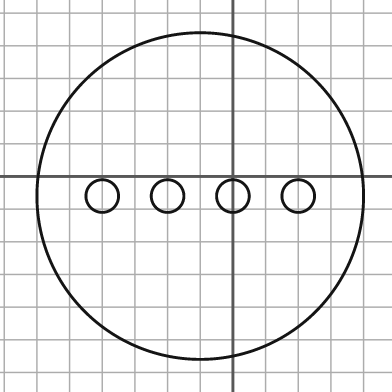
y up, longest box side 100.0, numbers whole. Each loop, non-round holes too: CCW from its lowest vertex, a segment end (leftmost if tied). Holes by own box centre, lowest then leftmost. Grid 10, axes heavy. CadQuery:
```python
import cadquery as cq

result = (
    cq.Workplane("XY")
    .moveTo(-10.0, -6.0)
    .circle(50.0)
    .moveTo(-40.0, -6.0)
    .circle(5.0)
    .moveTo(-20.0, -6.0)
    .circle(5.0)
    .moveTo(0.0, -6.0)
    .circle(5.0)
    .moveTo(20.0, -6.0)
    .circle(5.0)
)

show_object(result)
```